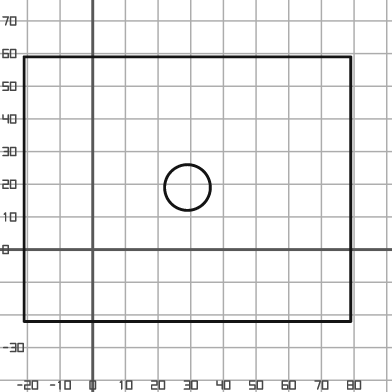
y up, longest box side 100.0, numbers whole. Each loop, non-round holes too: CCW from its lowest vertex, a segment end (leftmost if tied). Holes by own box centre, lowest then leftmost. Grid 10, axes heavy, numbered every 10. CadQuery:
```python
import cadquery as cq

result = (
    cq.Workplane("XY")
    .moveTo(-21.0, -22.0)
    .lineTo(79.0, -22.0)
    .lineTo(79.0, 59.0)
    .lineTo(-21.0, 59.0)
    .close()
    .moveTo(29.0, 19.0)
    .circle(7.0)
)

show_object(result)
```